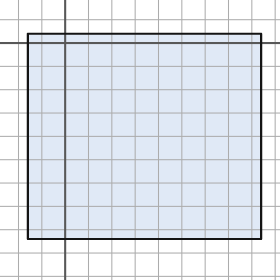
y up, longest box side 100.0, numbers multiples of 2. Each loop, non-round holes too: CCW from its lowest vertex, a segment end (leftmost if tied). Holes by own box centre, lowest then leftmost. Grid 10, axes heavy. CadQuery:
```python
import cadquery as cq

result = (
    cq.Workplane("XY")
    .moveTo(-16.0, -84.0)
    .lineTo(84.0, -84.0)
    .lineTo(84.0, 4.0)
    .lineTo(-16.0, 4.0)
    .close()
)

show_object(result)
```